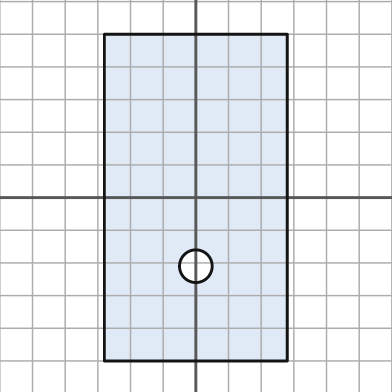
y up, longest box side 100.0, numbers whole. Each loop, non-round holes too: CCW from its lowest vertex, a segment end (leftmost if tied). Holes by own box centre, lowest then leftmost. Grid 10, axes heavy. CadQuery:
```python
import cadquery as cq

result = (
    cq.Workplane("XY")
    .moveTo(-28.0, -50.0)
    .lineTo(28.0, -50.0)
    .lineTo(28.0, 50.0)
    .lineTo(-28.0, 50.0)
    .close()
    .moveTo(0.0, -21.0)
    .circle(5.0)
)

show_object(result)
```